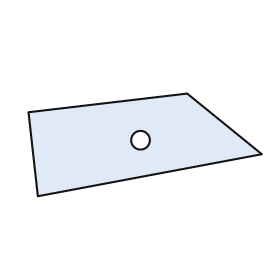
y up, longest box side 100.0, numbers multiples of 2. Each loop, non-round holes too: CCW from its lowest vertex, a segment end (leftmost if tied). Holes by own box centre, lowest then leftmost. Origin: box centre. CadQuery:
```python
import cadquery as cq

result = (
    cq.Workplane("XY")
    .moveTo(-46.0, -22.0)
    .lineTo(50.0, -4.0)
    .lineTo(18.0, 22.0)
    .lineTo(-50.0, 14.0)
    .close()
    .moveTo(-2.0, 2.0)
    .circle(4.0)
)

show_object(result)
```